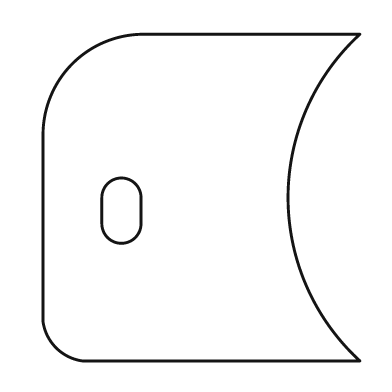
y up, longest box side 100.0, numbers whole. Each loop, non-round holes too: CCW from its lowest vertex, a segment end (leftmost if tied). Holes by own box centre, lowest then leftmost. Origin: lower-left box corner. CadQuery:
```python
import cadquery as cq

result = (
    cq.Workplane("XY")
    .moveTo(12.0, 0.0)
    .lineTo(97.0, 0.0)
    .threePointArc((75.0, 50.0), (97.0, 100.0))
    .lineTo(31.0, 100.0)
    .threePointArc((9.0, 91.0), (0.0, 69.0))
    .lineTo(0.0, 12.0)
    .threePointArc((4.0, 4.0), (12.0, 0.0))
    .close()
    .moveTo(18.0, 42.0)
    .threePointArc((24.0, 36.0), (30.0, 42.0))
    .lineTo(30.0, 50.0)
    .threePointArc((24.0, 56.0), (18.0, 50.0))
    .close()
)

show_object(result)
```